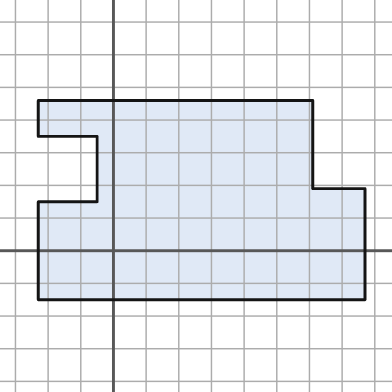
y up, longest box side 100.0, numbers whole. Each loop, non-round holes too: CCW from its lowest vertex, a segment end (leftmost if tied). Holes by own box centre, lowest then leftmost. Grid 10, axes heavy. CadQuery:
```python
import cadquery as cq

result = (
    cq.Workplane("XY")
    .moveTo(-23.0, -15.0)
    .lineTo(77.0, -15.0)
    .lineTo(77.0, 19.0)
    .lineTo(61.0, 19.0)
    .lineTo(61.0, 46.0)
    .lineTo(-23.0, 46.0)
    .lineTo(-23.0, 35.0)
    .lineTo(-5.0, 35.0)
    .lineTo(-5.0, 15.0)
    .lineTo(-23.0, 15.0)
    .close()
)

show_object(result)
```